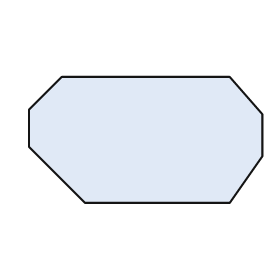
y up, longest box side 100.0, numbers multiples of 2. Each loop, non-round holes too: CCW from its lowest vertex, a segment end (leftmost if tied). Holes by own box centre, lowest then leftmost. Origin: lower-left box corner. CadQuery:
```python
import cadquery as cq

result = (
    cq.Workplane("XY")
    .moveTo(24.0, 0.0)
    .lineTo(86.0, 0.0)
    .lineTo(100.0, 20.0)
    .lineTo(100.0, 38.0)
    .lineTo(86.0, 54.0)
    .lineTo(14.0, 54.0)
    .lineTo(0.0, 40.0)
    .lineTo(0.0, 24.0)
    .close()
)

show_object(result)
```